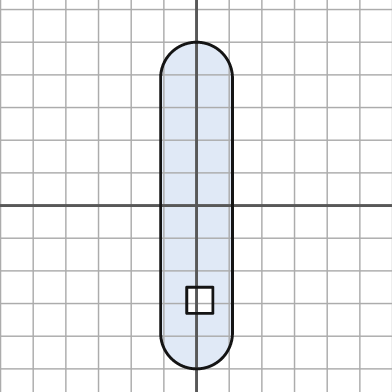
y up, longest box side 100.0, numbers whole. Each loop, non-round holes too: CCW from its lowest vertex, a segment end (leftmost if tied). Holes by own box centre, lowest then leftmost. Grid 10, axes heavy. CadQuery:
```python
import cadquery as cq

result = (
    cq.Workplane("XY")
    .moveTo(-11.0, -39.0)
    .threePointArc((0.0, -50.0), (11.0, -39.0))
    .lineTo(11.0, 39.0)
    .threePointArc((0.0, 50.0), (-11.0, 39.0))
    .close()
    .moveTo(-3.0, -33.0)
    .lineTo(5.0, -33.0)
    .lineTo(5.0, -25.0)
    .lineTo(-3.0, -25.0)
    .close()
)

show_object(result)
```